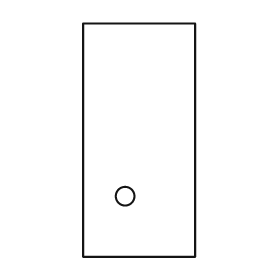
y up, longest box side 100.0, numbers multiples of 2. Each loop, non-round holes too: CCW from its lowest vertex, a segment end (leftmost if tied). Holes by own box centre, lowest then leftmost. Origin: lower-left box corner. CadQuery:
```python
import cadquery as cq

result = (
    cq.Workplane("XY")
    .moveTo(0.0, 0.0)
    .lineTo(48.0, 0.0)
    .lineTo(48.0, 100.0)
    .lineTo(0.0, 100.0)
    .close()
    .moveTo(18.0, 26.0)
    .circle(4.0)
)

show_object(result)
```